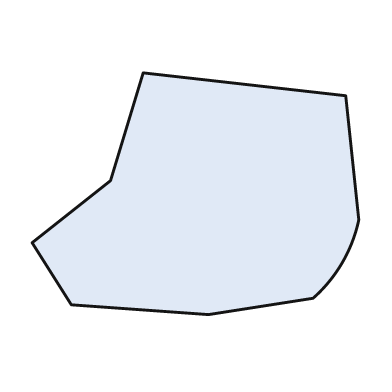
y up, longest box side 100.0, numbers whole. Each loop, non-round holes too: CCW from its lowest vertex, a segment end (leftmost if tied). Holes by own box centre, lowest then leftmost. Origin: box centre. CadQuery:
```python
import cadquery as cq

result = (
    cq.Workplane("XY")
    .moveTo(4.0, -37.0)
    .lineTo(36.0, -32.0)
    .threePointArc((45.0, -21.0), (50.0, -8.0))
    .lineTo(46.0, 30.0)
    .lineTo(-16.0, 37.0)
    .lineTo(-26.0, 4.0)
    .lineTo(-50.0, -15.0)
    .lineTo(-38.0, -34.0)
    .close()
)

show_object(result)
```